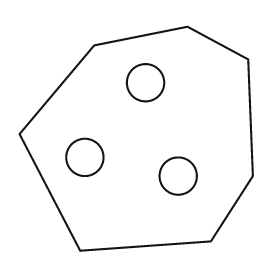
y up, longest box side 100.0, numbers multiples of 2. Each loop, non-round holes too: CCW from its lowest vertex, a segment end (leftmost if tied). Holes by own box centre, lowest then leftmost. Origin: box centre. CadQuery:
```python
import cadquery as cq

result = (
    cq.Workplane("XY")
    .moveTo(-24.0, -48.0)
    .lineTo(32.0, -44.0)
    .lineTo(50.0, -16.0)
    .lineTo(48.0, 34.0)
    .lineTo(22.0, 48.0)
    .lineTo(-18.0, 40.0)
    .lineTo(-50.0, 2.0)
    .close()
    .moveTo(18.0, -16.0)
    .circle(8.0)
    .moveTo(-22.0, -8.0)
    .circle(8.0)
    .moveTo(4.0, 24.0)
    .circle(8.0)
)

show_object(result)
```